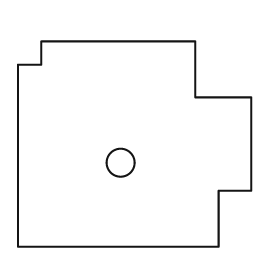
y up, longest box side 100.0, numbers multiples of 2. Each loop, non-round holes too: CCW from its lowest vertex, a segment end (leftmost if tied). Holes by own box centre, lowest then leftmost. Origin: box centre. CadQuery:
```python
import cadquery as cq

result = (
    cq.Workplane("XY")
    .moveTo(-50.0, -44.0)
    .lineTo(36.0, -44.0)
    .lineTo(36.0, -20.0)
    .lineTo(50.0, -20.0)
    .lineTo(50.0, 20.0)
    .lineTo(26.0, 20.0)
    .lineTo(26.0, 44.0)
    .lineTo(-40.0, 44.0)
    .lineTo(-40.0, 34.0)
    .lineTo(-50.0, 34.0)
    .close()
    .moveTo(-6.0, -8.0)
    .circle(6.0)
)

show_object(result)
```